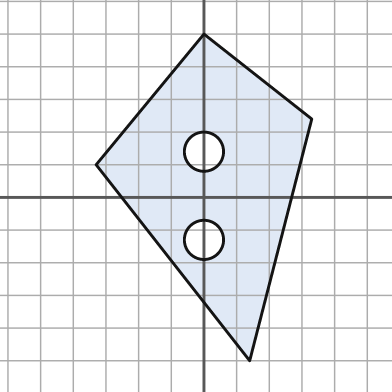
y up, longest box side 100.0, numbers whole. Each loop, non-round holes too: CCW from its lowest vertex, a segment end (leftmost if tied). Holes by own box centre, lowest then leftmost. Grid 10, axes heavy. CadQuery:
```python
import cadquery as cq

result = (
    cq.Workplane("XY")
    .moveTo(14.0, -50.0)
    .lineTo(33.0, 24.0)
    .lineTo(0.0, 50.0)
    .lineTo(-33.0, 10.0)
    .close()
    .moveTo(0.0, -13.0)
    .circle(6.0)
    .moveTo(0.0, 14.0)
    .circle(6.0)
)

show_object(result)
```